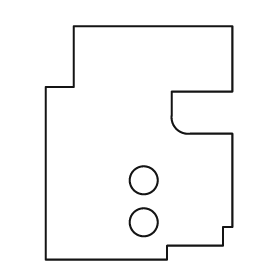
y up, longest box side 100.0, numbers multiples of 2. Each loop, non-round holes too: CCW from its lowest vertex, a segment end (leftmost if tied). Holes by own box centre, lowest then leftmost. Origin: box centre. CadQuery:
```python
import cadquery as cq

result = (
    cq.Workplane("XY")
    .moveTo(-40.0, -50.0)
    .lineTo(12.0, -50.0)
    .lineTo(12.0, -44.0)
    .lineTo(36.0, -44.0)
    .lineTo(36.0, -36.0)
    .lineTo(40.0, -36.0)
    .lineTo(40.0, 4.0)
    .lineTo(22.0, 4.0)
    .threePointArc((16.0, 6.0), (14.0, 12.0))
    .lineTo(14.0, 22.0)
    .lineTo(40.0, 22.0)
    .lineTo(40.0, 50.0)
    .lineTo(-28.0, 50.0)
    .lineTo(-28.0, 24.0)
    .lineTo(-40.0, 24.0)
    .close()
    .moveTo(2.0, -34.0)
    .circle(6.0)
    .moveTo(2.0, -16.0)
    .circle(6.0)
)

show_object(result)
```